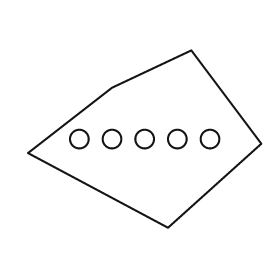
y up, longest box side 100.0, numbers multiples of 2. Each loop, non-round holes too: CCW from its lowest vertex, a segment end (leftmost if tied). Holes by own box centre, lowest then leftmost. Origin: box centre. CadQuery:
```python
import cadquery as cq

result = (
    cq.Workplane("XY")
    .moveTo(10.0, -38.0)
    .lineTo(50.0, -2.0)
    .lineTo(20.0, 38.0)
    .lineTo(-14.0, 22.0)
    .lineTo(-50.0, -6.0)
    .close()
    .moveTo(-28.0, 0.0)
    .circle(4.0)
    .moveTo(-14.0, 0.0)
    .circle(4.0)
    .moveTo(0.0, 0.0)
    .circle(4.0)
    .moveTo(14.0, 0.0)
    .circle(4.0)
    .moveTo(28.0, 0.0)
    .circle(4.0)
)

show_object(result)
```